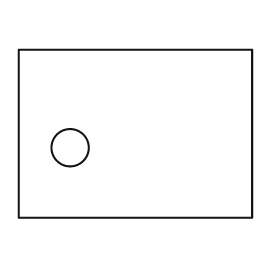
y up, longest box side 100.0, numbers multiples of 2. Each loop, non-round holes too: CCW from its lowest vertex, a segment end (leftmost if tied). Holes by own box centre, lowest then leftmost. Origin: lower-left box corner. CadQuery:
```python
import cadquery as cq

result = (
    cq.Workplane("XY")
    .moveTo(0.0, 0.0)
    .lineTo(100.0, 0.0)
    .lineTo(100.0, 72.0)
    .lineTo(0.0, 72.0)
    .close()
    .moveTo(22.0, 30.0)
    .circle(8.0)
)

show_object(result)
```